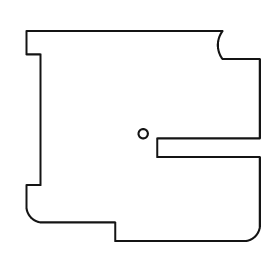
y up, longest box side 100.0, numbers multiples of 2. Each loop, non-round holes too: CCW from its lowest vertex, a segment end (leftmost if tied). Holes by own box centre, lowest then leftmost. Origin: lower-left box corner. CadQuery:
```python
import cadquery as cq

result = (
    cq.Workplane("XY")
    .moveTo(38.0, 0.0)
    .lineTo(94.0, 0.0)
    .threePointArc((98.0, 2.0), (100.0, 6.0))
    .lineTo(100.0, 36.0)
    .lineTo(56.0, 36.0)
    .lineTo(56.0, 44.0)
    .lineTo(100.0, 44.0)
    .lineTo(100.0, 78.0)
    .lineTo(84.0, 78.0)
    .threePointArc((82.0, 84.0), (84.0, 90.0))
    .lineTo(0.0, 90.0)
    .lineTo(0.0, 80.0)
    .lineTo(6.0, 80.0)
    .lineTo(6.0, 24.0)
    .lineTo(0.0, 24.0)
    .lineTo(0.0, 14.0)
    .threePointArc((2.0, 10.0), (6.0, 8.0))
    .lineTo(38.0, 8.0)
    .close()
    .moveTo(50.0, 46.0)
    .circle(2.0)
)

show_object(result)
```